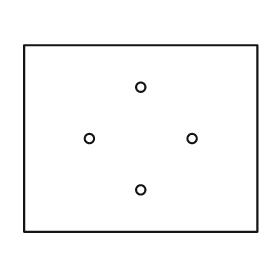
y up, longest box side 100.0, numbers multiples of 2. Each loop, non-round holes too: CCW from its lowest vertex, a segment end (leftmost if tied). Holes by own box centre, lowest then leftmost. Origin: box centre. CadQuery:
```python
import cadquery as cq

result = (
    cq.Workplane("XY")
    .moveTo(-50.0, -40.0)
    .lineTo(50.0, -40.0)
    .lineTo(50.0, 40.0)
    .lineTo(-50.0, 40.0)
    .close()
    .moveTo(0.0, -22.0)
    .circle(2.0)
    .moveTo(-22.0, 0.0)
    .circle(2.0)
    .moveTo(22.0, 0.0)
    .circle(2.0)
    .moveTo(0.0, 22.0)
    .circle(2.0)
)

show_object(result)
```